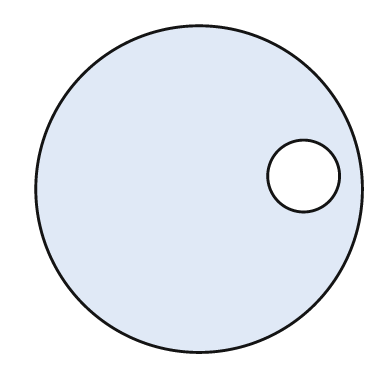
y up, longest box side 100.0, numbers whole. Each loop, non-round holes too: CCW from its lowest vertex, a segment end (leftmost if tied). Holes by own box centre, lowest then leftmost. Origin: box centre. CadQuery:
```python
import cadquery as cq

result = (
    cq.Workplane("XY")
    .moveTo(0.0, 0.0)
    .circle(50.0)
    .moveTo(32.0, 4.0)
    .circle(11.0)
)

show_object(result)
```